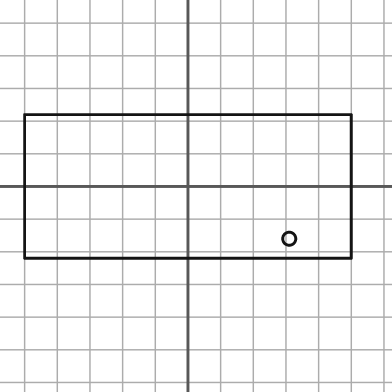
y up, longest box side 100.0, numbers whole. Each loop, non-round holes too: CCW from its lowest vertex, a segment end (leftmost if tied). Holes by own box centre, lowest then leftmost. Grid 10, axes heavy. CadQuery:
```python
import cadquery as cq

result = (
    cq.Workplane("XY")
    .moveTo(-50.0, -22.0)
    .lineTo(50.0, -22.0)
    .lineTo(50.0, 22.0)
    .lineTo(-50.0, 22.0)
    .close()
    .moveTo(31.0, -16.0)
    .circle(2.0)
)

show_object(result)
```